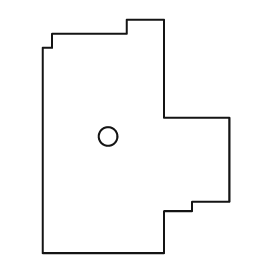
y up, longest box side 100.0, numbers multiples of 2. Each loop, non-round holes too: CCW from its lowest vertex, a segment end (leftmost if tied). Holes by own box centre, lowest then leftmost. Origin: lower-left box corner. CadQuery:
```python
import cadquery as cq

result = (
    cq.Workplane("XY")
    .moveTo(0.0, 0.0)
    .lineTo(52.0, 0.0)
    .lineTo(52.0, 18.0)
    .lineTo(64.0, 18.0)
    .lineTo(64.0, 22.0)
    .lineTo(80.0, 22.0)
    .lineTo(80.0, 58.0)
    .lineTo(52.0, 58.0)
    .lineTo(52.0, 100.0)
    .lineTo(36.0, 100.0)
    .lineTo(36.0, 94.0)
    .lineTo(4.0, 94.0)
    .lineTo(4.0, 88.0)
    .lineTo(0.0, 88.0)
    .close()
    .moveTo(28.0, 50.0)
    .circle(4.0)
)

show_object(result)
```